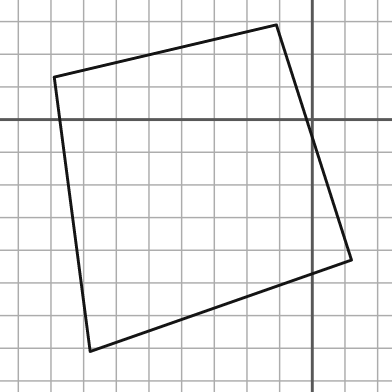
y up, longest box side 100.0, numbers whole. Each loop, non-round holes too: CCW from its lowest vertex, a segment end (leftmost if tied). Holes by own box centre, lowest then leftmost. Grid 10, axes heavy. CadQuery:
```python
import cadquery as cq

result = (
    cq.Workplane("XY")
    .moveTo(-68.0, -71.0)
    .lineTo(12.0, -43.0)
    .lineTo(-11.0, 29.0)
    .lineTo(-79.0, 13.0)
    .close()
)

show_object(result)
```